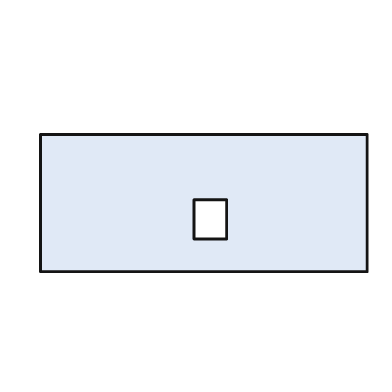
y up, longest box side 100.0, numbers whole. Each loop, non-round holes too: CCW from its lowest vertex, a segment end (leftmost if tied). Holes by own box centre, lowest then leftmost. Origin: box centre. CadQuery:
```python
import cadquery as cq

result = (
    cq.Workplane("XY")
    .moveTo(-50.0, -21.0)
    .lineTo(50.0, -21.0)
    .lineTo(50.0, 21.0)
    .lineTo(-50.0, 21.0)
    .close()
    .moveTo(-3.0, -11.0)
    .lineTo(7.0, -11.0)
    .lineTo(7.0, 1.0)
    .lineTo(-3.0, 1.0)
    .close()
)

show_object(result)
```